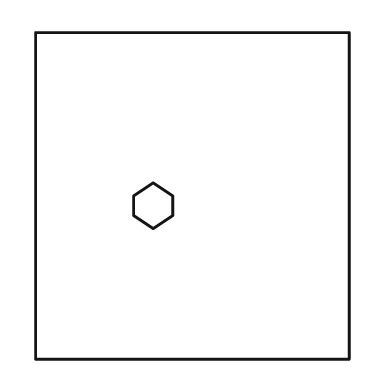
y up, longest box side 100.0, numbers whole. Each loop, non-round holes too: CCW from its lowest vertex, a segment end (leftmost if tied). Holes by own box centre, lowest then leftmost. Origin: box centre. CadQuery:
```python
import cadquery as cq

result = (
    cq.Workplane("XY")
    .moveTo(-48.0, -50.0)
    .lineTo(48.0, -50.0)
    .lineTo(48.0, 50.0)
    .lineTo(-48.0, 50.0)
    .close()
    .moveTo(-12.0, -10.0)
    .lineTo(-6.0, -6.0)
    .lineTo(-6.0, 0.0)
    .lineTo(-12.0, 4.0)
    .lineTo(-18.0, 0.0)
    .lineTo(-18.0, -6.0)
    .close()
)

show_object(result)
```